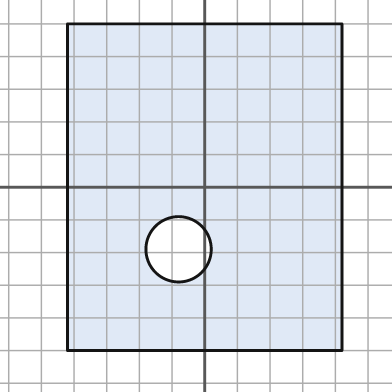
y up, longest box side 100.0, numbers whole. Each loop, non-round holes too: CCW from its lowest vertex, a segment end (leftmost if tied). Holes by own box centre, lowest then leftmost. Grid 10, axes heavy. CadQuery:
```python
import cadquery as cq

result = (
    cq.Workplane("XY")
    .moveTo(-42.0, -50.0)
    .lineTo(42.0, -50.0)
    .lineTo(42.0, 50.0)
    .lineTo(-42.0, 50.0)
    .close()
    .moveTo(-8.0, -19.0)
    .circle(10.0)
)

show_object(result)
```